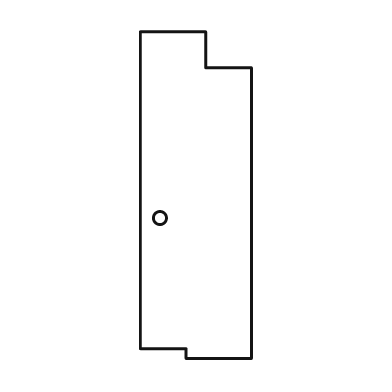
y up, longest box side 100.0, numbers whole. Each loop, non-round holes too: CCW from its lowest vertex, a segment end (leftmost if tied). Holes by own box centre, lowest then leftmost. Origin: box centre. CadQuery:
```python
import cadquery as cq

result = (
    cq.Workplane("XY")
    .moveTo(-3.0, -50.0)
    .lineTo(17.0, -50.0)
    .lineTo(17.0, 39.0)
    .lineTo(3.0, 39.0)
    .lineTo(3.0, 50.0)
    .lineTo(-17.0, 50.0)
    .lineTo(-17.0, -47.0)
    .lineTo(-3.0, -47.0)
    .close()
    .moveTo(-11.0, -7.0)
    .circle(2.0)
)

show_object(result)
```